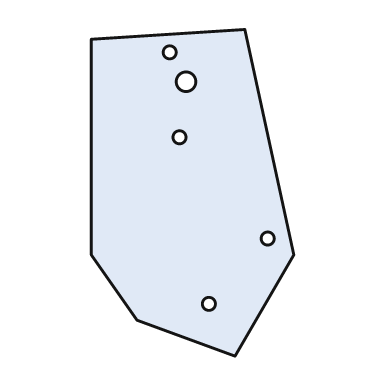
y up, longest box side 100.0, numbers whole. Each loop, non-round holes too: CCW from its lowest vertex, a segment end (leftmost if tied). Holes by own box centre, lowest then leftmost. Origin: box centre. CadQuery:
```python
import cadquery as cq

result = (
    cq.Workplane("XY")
    .moveTo(13.0, -50.0)
    .lineTo(31.0, -19.0)
    .lineTo(16.0, 50.0)
    .lineTo(-31.0, 47.0)
    .lineTo(-31.0, -19.0)
    .lineTo(-17.0, -39.0)
    .close()
    .moveTo(5.0, -34.0)
    .circle(2.0)
    .moveTo(23.0, -14.0)
    .circle(2.0)
    .moveTo(-4.0, 17.0)
    .circle(2.0)
    .moveTo(-2.0, 34.0)
    .circle(3.0)
    .moveTo(-7.0, 43.0)
    .circle(2.0)
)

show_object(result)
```